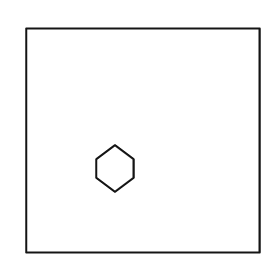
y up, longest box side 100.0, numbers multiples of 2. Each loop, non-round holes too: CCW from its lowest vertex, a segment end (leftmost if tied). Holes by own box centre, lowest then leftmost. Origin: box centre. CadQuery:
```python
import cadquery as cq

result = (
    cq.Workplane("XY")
    .moveTo(-50.0, -48.0)
    .lineTo(50.0, -48.0)
    .lineTo(50.0, 48.0)
    .lineTo(-50.0, 48.0)
    .close()
    .moveTo(-12.0, -22.0)
    .lineTo(-4.0, -16.0)
    .lineTo(-4.0, -8.0)
    .lineTo(-12.0, -2.0)
    .lineTo(-20.0, -8.0)
    .lineTo(-20.0, -16.0)
    .close()
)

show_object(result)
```